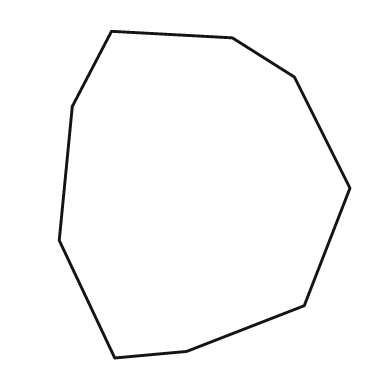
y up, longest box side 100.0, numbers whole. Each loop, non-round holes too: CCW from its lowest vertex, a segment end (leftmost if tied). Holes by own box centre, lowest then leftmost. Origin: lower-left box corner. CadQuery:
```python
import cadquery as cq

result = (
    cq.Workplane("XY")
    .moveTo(17.0, 0.0)
    .lineTo(39.0, 2.0)
    .lineTo(75.0, 16.0)
    .lineTo(89.0, 52.0)
    .lineTo(72.0, 86.0)
    .lineTo(53.0, 98.0)
    .lineTo(16.0, 100.0)
    .lineTo(4.0, 77.0)
    .lineTo(0.0, 36.0)
    .close()
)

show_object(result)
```